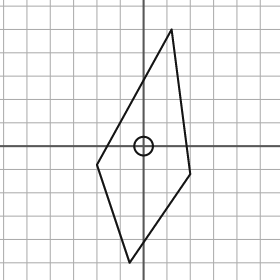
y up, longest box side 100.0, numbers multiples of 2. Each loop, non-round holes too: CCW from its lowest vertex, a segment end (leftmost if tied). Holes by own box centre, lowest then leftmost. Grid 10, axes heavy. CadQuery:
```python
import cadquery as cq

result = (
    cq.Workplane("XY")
    .moveTo(-6.0, -50.0)
    .lineTo(20.0, -12.0)
    .lineTo(12.0, 50.0)
    .lineTo(-20.0, -8.0)
    .close()
    .moveTo(0.0, 0.0)
    .circle(4.0)
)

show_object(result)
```